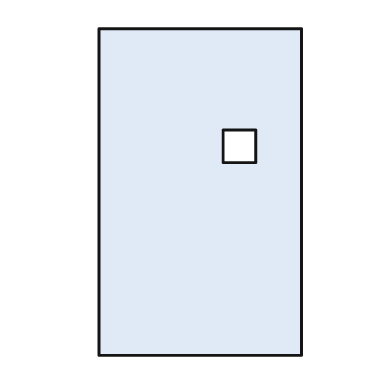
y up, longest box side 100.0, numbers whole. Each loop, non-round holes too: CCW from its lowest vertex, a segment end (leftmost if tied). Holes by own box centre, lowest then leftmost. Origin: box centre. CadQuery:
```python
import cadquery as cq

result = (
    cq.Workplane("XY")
    .moveTo(-31.0, -50.0)
    .lineTo(31.0, -50.0)
    .lineTo(31.0, 50.0)
    .lineTo(-31.0, 50.0)
    .close()
    .moveTo(7.0, 9.0)
    .lineTo(17.0, 9.0)
    .lineTo(17.0, 19.0)
    .lineTo(7.0, 19.0)
    .close()
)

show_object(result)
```